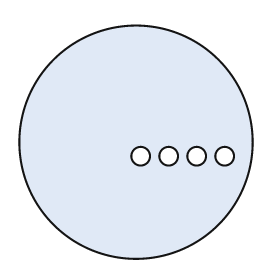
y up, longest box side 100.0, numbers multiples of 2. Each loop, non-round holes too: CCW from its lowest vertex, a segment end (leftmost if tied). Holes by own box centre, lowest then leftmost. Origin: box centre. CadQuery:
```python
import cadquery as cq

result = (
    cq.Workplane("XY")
    .moveTo(0.0, 0.0)
    .circle(50.0)
    .moveTo(2.0, -6.0)
    .circle(4.0)
    .moveTo(14.0, -6.0)
    .circle(4.0)
    .moveTo(26.0, -6.0)
    .circle(4.0)
    .moveTo(38.0, -6.0)
    .circle(4.0)
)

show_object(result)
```